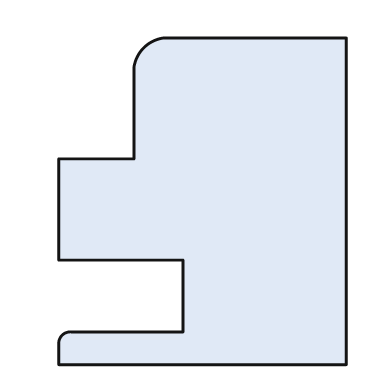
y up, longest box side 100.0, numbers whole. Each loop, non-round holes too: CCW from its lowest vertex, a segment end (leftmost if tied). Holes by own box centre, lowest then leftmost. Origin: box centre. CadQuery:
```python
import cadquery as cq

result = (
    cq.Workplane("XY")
    .moveTo(-44.0, -50.0)
    .lineTo(44.0, -50.0)
    .lineTo(44.0, 50.0)
    .lineTo(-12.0, 50.0)
    .threePointArc((-18.0, 47.0), (-21.0, 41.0))
    .lineTo(-21.0, 13.0)
    .lineTo(-44.0, 13.0)
    .lineTo(-44.0, -18.0)
    .lineTo(-6.0, -18.0)
    .lineTo(-6.0, -40.0)
    .lineTo(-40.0, -40.0)
    .threePointArc((-43.0, -41.0), (-44.0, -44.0))
    .close()
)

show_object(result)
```